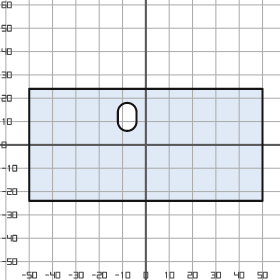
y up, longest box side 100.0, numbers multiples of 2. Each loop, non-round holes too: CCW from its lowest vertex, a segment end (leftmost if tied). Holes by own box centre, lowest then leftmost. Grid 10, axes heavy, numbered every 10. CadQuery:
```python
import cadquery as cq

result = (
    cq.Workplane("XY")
    .moveTo(-50.0, -24.0)
    .lineTo(50.0, -24.0)
    .lineTo(50.0, 24.0)
    .lineTo(-50.0, 24.0)
    .close()
    .moveTo(-12.0, 10.0)
    .threePointArc((-8.0, 6.0), (-4.0, 10.0))
    .lineTo(-4.0, 14.0)
    .threePointArc((-8.0, 18.0), (-12.0, 14.0))
    .close()
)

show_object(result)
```